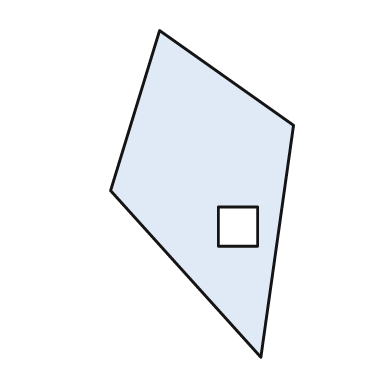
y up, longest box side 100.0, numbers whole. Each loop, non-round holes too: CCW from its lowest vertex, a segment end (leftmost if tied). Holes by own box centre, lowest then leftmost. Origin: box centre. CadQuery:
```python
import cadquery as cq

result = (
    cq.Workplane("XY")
    .moveTo(18.0, -50.0)
    .lineTo(28.0, 21.0)
    .lineTo(-13.0, 50.0)
    .lineTo(-28.0, 1.0)
    .close()
    .moveTo(5.0, -16.0)
    .lineTo(17.0, -16.0)
    .lineTo(17.0, -4.0)
    .lineTo(5.0, -4.0)
    .close()
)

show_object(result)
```